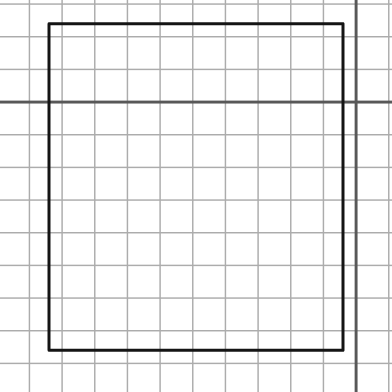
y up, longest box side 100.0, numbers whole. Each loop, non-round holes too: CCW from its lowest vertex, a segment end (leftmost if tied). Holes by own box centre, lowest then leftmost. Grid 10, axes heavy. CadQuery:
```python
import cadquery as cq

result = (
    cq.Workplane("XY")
    .moveTo(-94.0, -76.0)
    .lineTo(-4.0, -76.0)
    .lineTo(-4.0, 24.0)
    .lineTo(-94.0, 24.0)
    .close()
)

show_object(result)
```